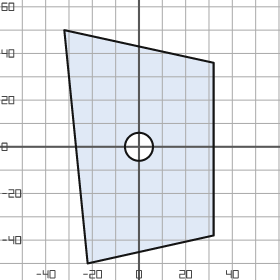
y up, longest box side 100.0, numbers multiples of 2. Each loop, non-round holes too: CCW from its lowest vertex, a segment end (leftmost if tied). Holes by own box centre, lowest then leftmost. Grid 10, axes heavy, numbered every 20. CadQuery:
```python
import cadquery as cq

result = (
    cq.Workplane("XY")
    .moveTo(-22.0, -50.0)
    .lineTo(32.0, -38.0)
    .lineTo(32.0, 36.0)
    .lineTo(-32.0, 50.0)
    .close()
    .moveTo(0.0, 0.0)
    .circle(6.0)
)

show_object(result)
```